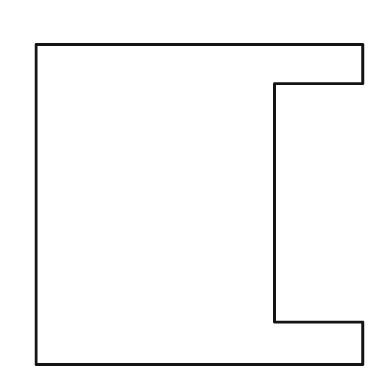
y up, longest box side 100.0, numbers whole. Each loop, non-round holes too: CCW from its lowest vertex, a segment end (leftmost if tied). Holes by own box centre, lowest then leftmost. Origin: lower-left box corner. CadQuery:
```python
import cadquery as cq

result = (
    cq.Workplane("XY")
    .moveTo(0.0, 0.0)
    .lineTo(100.0, 0.0)
    .lineTo(100.0, 13.0)
    .lineTo(73.0, 13.0)
    .lineTo(73.0, 86.0)
    .lineTo(100.0, 86.0)
    .lineTo(100.0, 98.0)
    .lineTo(0.0, 98.0)
    .close()
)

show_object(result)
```